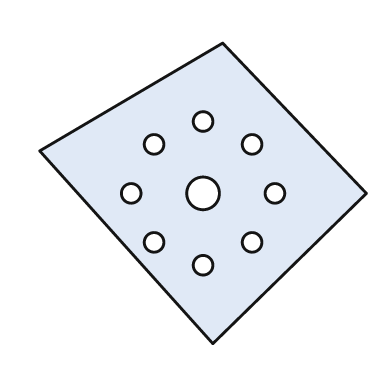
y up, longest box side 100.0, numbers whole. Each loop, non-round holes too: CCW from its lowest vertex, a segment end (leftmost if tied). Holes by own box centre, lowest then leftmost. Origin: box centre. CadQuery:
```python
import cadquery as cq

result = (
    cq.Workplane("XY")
    .moveTo(3.0, -46.0)
    .lineTo(50.0, 0.0)
    .lineTo(6.0, 46.0)
    .lineTo(-50.0, 13.0)
    .close()
    .moveTo(0.0, -22.0)
    .circle(3.0)
    .moveTo(-15.0, -15.0)
    .circle(3.0)
    .moveTo(15.0, -15.0)
    .circle(3.0)
    .moveTo(-22.0, 0.0)
    .circle(3.0)
    .moveTo(0.0, 0.0)
    .circle(5.0)
    .moveTo(22.0, 0.0)
    .circle(3.0)
    .moveTo(-15.0, 15.0)
    .circle(3.0)
    .moveTo(15.0, 15.0)
    .circle(3.0)
    .moveTo(0.0, 22.0)
    .circle(3.0)
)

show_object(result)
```